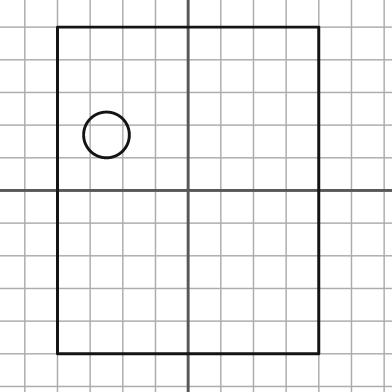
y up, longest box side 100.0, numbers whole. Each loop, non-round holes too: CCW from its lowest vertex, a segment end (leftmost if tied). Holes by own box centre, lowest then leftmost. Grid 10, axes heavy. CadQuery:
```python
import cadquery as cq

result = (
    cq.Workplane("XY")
    .moveTo(-40.0, -50.0)
    .lineTo(40.0, -50.0)
    .lineTo(40.0, 50.0)
    .lineTo(-40.0, 50.0)
    .close()
    .moveTo(-25.0, 17.0)
    .circle(7.0)
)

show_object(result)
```